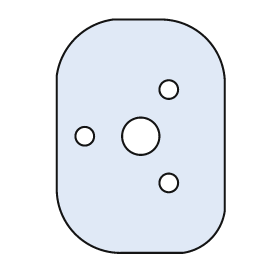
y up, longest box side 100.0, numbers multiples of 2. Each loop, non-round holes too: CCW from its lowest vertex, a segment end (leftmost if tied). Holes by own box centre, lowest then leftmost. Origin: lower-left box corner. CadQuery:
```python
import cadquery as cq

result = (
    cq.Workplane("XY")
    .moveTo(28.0, 0.0)
    .lineTo(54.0, 0.0)
    .threePointArc((66.0, 6.0), (72.0, 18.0))
    .lineTo(72.0, 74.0)
    .threePointArc((64.0, 92.0), (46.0, 100.0))
    .lineTo(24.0, 100.0)
    .threePointArc((8.0, 92.0), (0.0, 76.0))
    .lineTo(0.0, 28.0)
    .threePointArc((8.0, 8.0), (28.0, 0.0))
    .close()
    .moveTo(48.0, 30.0)
    .circle(4.0)
    .moveTo(12.0, 50.0)
    .circle(4.0)
    .moveTo(36.0, 50.0)
    .circle(8.0)
    .moveTo(48.0, 70.0)
    .circle(4.0)
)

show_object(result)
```